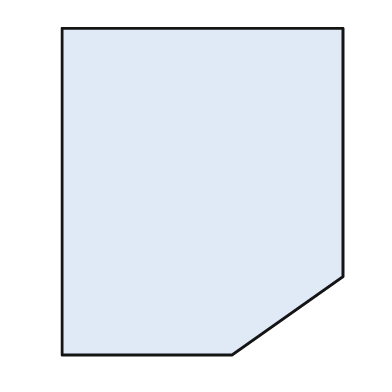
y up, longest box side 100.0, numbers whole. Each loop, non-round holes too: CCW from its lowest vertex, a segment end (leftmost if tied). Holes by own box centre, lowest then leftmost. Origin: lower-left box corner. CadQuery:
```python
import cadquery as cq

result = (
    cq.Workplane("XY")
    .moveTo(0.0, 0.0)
    .lineTo(52.0, 0.0)
    .lineTo(86.0, 24.0)
    .lineTo(86.0, 100.0)
    .lineTo(0.0, 100.0)
    .close()
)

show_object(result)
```